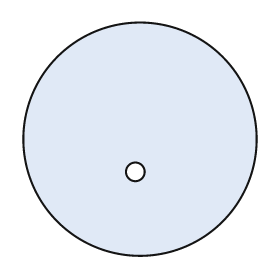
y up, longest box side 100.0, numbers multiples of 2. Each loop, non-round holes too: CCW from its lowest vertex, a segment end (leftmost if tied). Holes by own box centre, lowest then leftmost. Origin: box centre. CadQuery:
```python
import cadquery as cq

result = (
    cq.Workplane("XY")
    .moveTo(0.0, 0.0)
    .circle(50.0)
    .moveTo(-2.0, -14.0)
    .circle(4.0)
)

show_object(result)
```